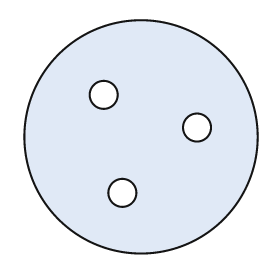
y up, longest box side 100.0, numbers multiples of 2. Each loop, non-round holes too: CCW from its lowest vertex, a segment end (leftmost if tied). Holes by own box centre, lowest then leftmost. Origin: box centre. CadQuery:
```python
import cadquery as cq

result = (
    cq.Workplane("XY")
    .moveTo(0.0, 0.0)
    .circle(50.0)
    .moveTo(-8.0, -24.0)
    .circle(6.0)
    .moveTo(24.0, 4.0)
    .circle(6.0)
    .moveTo(-16.0, 18.0)
    .circle(6.0)
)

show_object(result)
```